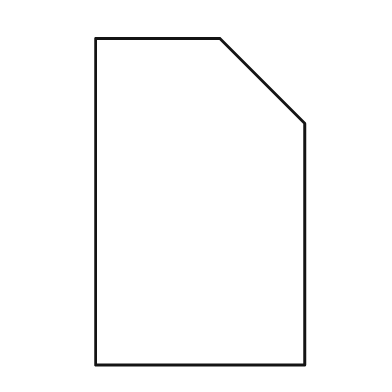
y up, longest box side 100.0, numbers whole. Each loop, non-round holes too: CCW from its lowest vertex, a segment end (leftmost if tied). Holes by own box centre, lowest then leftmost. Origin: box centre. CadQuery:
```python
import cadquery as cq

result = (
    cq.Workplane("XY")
    .moveTo(-32.0, -50.0)
    .lineTo(32.0, -50.0)
    .lineTo(32.0, 24.0)
    .lineTo(6.0, 50.0)
    .lineTo(-32.0, 50.0)
    .close()
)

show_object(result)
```